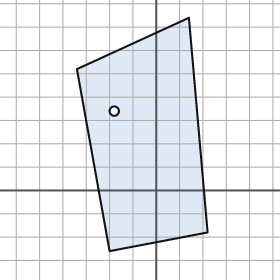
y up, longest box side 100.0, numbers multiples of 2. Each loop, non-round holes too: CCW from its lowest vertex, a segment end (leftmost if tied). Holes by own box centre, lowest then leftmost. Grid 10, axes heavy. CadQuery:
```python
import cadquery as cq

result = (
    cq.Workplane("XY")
    .moveTo(-20.0, -26.0)
    .lineTo(22.0, -18.0)
    .lineTo(14.0, 74.0)
    .lineTo(-34.0, 52.0)
    .close()
    .moveTo(-18.0, 34.0)
    .circle(2.0)
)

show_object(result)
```